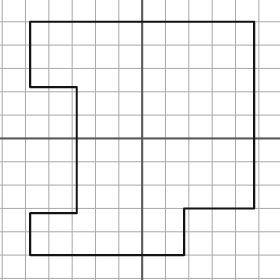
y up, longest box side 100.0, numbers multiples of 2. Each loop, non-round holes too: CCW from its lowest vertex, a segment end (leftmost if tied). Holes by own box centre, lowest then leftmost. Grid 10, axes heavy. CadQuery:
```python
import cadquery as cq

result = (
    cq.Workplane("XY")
    .moveTo(-48.0, -50.0)
    .lineTo(18.0, -50.0)
    .lineTo(18.0, -30.0)
    .lineTo(48.0, -30.0)
    .lineTo(48.0, 50.0)
    .lineTo(-48.0, 50.0)
    .lineTo(-48.0, 22.0)
    .lineTo(-28.0, 22.0)
    .lineTo(-28.0, -32.0)
    .lineTo(-48.0, -32.0)
    .close()
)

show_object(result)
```